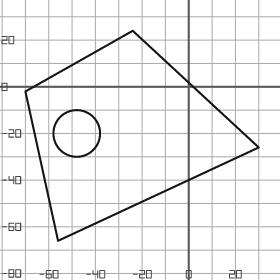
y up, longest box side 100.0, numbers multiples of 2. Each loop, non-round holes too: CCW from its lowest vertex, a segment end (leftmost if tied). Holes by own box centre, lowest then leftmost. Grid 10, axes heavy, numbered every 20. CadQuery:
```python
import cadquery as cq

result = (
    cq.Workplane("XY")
    .moveTo(-56.0, -66.0)
    .lineTo(30.0, -26.0)
    .lineTo(-24.0, 24.0)
    .lineTo(-70.0, -2.0)
    .close()
    .moveTo(-48.0, -20.0)
    .circle(10.0)
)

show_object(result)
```